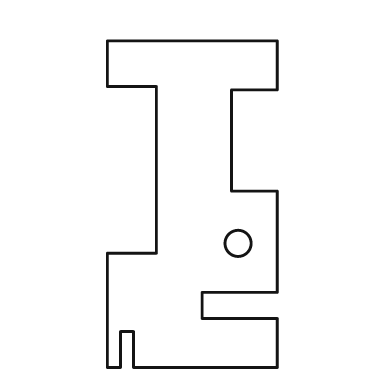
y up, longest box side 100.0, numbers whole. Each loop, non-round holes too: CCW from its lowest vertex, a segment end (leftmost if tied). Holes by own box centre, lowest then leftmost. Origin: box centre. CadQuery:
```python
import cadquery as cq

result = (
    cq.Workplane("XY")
    .moveTo(-26.0, -50.0)
    .lineTo(-22.0, -50.0)
    .lineTo(-22.0, -39.0)
    .lineTo(-18.0, -39.0)
    .lineTo(-18.0, -50.0)
    .lineTo(26.0, -50.0)
    .lineTo(26.0, -35.0)
    .lineTo(3.0, -35.0)
    .lineTo(3.0, -27.0)
    .lineTo(26.0, -27.0)
    .lineTo(26.0, 4.0)
    .lineTo(12.0, 4.0)
    .lineTo(12.0, 35.0)
    .lineTo(26.0, 35.0)
    .lineTo(26.0, 50.0)
    .lineTo(-26.0, 50.0)
    .lineTo(-26.0, 36.0)
    .lineTo(-11.0, 36.0)
    .lineTo(-11.0, -15.0)
    .lineTo(-26.0, -15.0)
    .close()
    .moveTo(14.0, -12.0)
    .circle(4.0)
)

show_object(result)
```